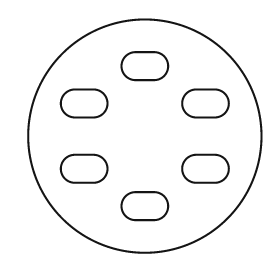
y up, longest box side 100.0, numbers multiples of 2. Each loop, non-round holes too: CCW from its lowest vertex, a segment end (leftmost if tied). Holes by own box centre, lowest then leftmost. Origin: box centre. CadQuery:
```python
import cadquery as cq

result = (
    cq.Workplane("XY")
    .moveTo(0.0, 0.0)
    .circle(50.0)
    .moveTo(-4.0, -36.0)
    .lineTo(4.0, -36.0)
    .threePointArc((10.0, -30.0), (4.0, -24.0))
    .lineTo(-4.0, -24.0)
    .threePointArc((-10.0, -30.0), (-4.0, -36.0))
    .close()
    .moveTo(-30.0, -20.0)
    .lineTo(-22.0, -20.0)
    .threePointArc((-16.0, -14.0), (-22.0, -8.0))
    .lineTo(-30.0, -8.0)
    .threePointArc((-36.0, -14.0), (-30.0, -20.0))
    .close()
    .moveTo(22.0, -20.0)
    .lineTo(30.0, -20.0)
    .threePointArc((36.0, -14.0), (30.0, -8.0))
    .lineTo(22.0, -8.0)
    .threePointArc((16.0, -14.0), (22.0, -20.0))
    .close()
    .moveTo(-30.0, 8.0)
    .lineTo(-22.0, 8.0)
    .threePointArc((-16.0, 14.0), (-22.0, 20.0))
    .lineTo(-30.0, 20.0)
    .threePointArc((-36.0, 14.0), (-30.0, 8.0))
    .close()
    .moveTo(22.0, 8.0)
    .lineTo(30.0, 8.0)
    .threePointArc((36.0, 14.0), (30.0, 20.0))
    .lineTo(22.0, 20.0)
    .threePointArc((16.0, 14.0), (22.0, 8.0))
    .close()
    .moveTo(-4.0, 24.0)
    .lineTo(4.0, 24.0)
    .threePointArc((10.0, 30.0), (4.0, 36.0))
    .lineTo(-4.0, 36.0)
    .threePointArc((-10.0, 30.0), (-4.0, 24.0))
    .close()
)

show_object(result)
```